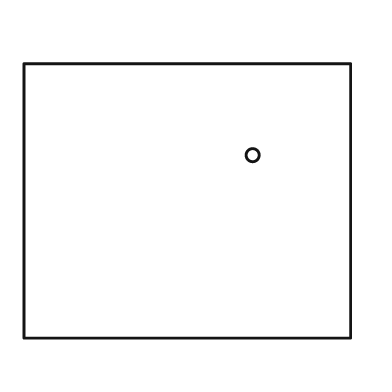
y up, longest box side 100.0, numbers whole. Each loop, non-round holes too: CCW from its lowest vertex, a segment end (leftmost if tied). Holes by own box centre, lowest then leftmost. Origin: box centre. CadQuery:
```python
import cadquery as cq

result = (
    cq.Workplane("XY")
    .moveTo(-50.0, -42.0)
    .lineTo(50.0, -42.0)
    .lineTo(50.0, 42.0)
    .lineTo(-50.0, 42.0)
    .close()
    .moveTo(20.0, 14.0)
    .circle(2.0)
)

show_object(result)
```